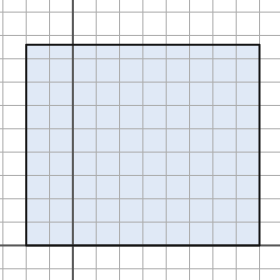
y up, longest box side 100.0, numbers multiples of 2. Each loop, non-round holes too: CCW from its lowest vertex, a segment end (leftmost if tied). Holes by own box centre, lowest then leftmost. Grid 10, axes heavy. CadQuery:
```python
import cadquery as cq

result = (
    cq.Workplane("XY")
    .moveTo(-20.0, 0.0)
    .lineTo(80.0, 0.0)
    .lineTo(80.0, 86.0)
    .lineTo(-20.0, 86.0)
    .close()
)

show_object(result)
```